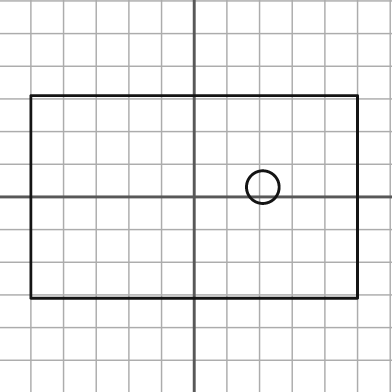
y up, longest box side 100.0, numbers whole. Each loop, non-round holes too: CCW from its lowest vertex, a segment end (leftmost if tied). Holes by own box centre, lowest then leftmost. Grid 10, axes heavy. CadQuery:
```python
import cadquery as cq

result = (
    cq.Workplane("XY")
    .moveTo(-50.0, -31.0)
    .lineTo(50.0, -31.0)
    .lineTo(50.0, 31.0)
    .lineTo(-50.0, 31.0)
    .close()
    .moveTo(21.0, 3.0)
    .circle(5.0)
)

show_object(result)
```